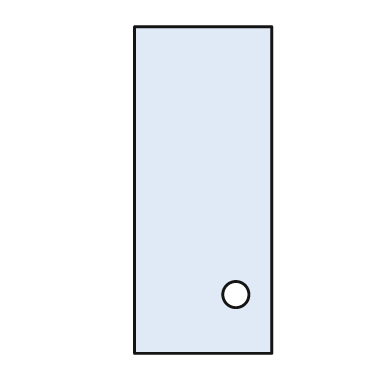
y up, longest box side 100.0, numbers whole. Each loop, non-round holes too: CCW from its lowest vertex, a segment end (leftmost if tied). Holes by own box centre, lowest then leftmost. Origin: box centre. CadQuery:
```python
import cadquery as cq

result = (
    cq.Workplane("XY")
    .moveTo(-21.0, -50.0)
    .lineTo(21.0, -50.0)
    .lineTo(21.0, 50.0)
    .lineTo(-21.0, 50.0)
    .close()
    .moveTo(10.0, -32.0)
    .circle(4.0)
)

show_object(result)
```